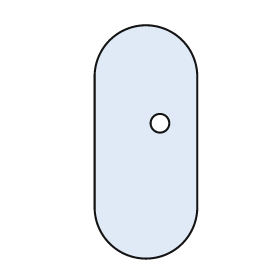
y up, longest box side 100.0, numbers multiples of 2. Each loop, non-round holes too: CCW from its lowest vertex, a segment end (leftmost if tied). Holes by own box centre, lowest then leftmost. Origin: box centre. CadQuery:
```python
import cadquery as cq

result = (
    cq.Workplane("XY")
    .moveTo(-22.0, -28.0)
    .threePointArc((0.0, -50.0), (22.0, -28.0))
    .lineTo(22.0, 28.0)
    .threePointArc((0.0, 50.0), (-22.0, 28.0))
    .close()
    .moveTo(6.0, 8.0)
    .circle(4.0)
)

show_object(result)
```